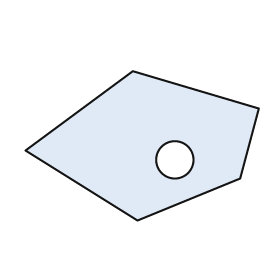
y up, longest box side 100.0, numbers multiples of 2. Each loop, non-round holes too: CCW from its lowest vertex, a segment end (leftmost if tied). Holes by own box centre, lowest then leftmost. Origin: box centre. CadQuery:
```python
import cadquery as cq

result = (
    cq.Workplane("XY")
    .moveTo(-2.0, -32.0)
    .lineTo(42.0, -14.0)
    .lineTo(50.0, 16.0)
    .lineTo(-4.0, 32.0)
    .lineTo(-50.0, -2.0)
    .close()
    .moveTo(14.0, -6.0)
    .circle(8.0)
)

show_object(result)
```